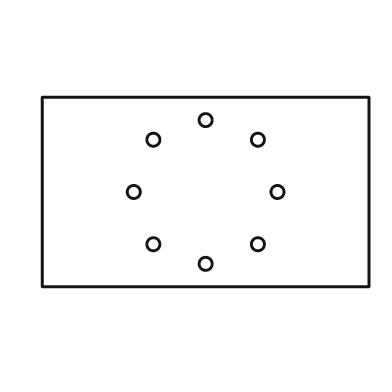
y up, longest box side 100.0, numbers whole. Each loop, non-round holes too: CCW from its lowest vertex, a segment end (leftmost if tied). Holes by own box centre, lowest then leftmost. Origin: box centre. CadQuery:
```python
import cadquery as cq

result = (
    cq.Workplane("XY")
    .moveTo(-50.0, -29.0)
    .lineTo(50.0, -29.0)
    .lineTo(50.0, 29.0)
    .lineTo(-50.0, 29.0)
    .close()
    .moveTo(0.0, -22.0)
    .circle(2.0)
    .moveTo(-16.0, -16.0)
    .circle(2.0)
    .moveTo(16.0, -16.0)
    .circle(2.0)
    .moveTo(-22.0, 0.0)
    .circle(2.0)
    .moveTo(22.0, 0.0)
    .circle(2.0)
    .moveTo(-16.0, 16.0)
    .circle(2.0)
    .moveTo(16.0, 16.0)
    .circle(2.0)
    .moveTo(0.0, 22.0)
    .circle(2.0)
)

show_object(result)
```